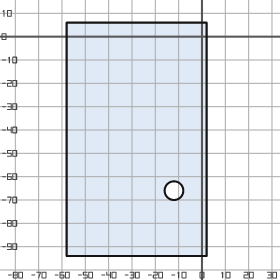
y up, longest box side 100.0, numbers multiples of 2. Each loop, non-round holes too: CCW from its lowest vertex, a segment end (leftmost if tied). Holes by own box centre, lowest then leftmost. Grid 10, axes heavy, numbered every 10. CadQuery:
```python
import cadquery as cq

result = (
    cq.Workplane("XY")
    .moveTo(-58.0, -94.0)
    .lineTo(2.0, -94.0)
    .lineTo(2.0, 6.0)
    .lineTo(-58.0, 6.0)
    .close()
    .moveTo(-12.0, -66.0)
    .circle(4.0)
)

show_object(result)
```